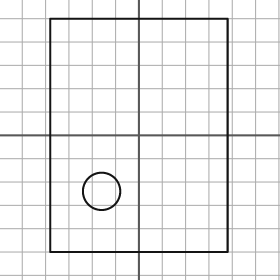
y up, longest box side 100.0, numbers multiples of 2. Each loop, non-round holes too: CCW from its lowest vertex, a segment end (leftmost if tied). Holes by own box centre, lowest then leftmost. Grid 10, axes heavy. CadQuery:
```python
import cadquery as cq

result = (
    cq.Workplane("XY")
    .moveTo(-38.0, -50.0)
    .lineTo(38.0, -50.0)
    .lineTo(38.0, 50.0)
    .lineTo(-38.0, 50.0)
    .close()
    .moveTo(-16.0, -24.0)
    .circle(8.0)
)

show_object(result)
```